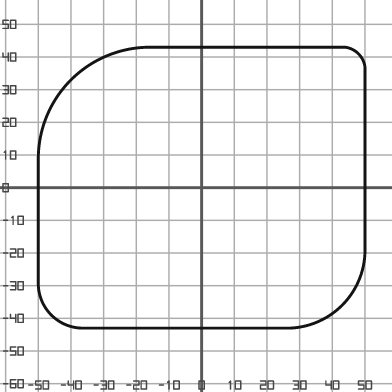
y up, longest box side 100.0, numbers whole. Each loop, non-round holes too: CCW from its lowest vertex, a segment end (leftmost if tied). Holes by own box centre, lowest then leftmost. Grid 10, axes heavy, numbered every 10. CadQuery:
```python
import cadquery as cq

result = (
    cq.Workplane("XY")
    .moveTo(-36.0, -43.0)
    .lineTo(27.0, -43.0)
    .threePointArc((43.0, -36.0), (50.0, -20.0))
    .lineTo(50.0, 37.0)
    .threePointArc((48.0, 41.0), (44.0, 43.0))
    .lineTo(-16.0, 43.0)
    .threePointArc((-40.0, 33.0), (-50.0, 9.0))
    .lineTo(-50.0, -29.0)
    .threePointArc((-46.0, -39.0), (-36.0, -43.0))
    .close()
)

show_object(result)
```